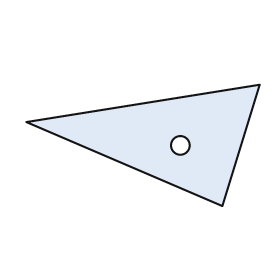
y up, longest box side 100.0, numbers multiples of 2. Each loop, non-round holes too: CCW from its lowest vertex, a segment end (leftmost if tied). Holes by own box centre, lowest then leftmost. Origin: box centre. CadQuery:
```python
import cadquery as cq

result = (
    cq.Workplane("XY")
    .moveTo(34.0, -26.0)
    .lineTo(50.0, 26.0)
    .lineTo(-50.0, 10.0)
    .close()
    .moveTo(16.0, 0.0)
    .circle(4.0)
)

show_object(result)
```